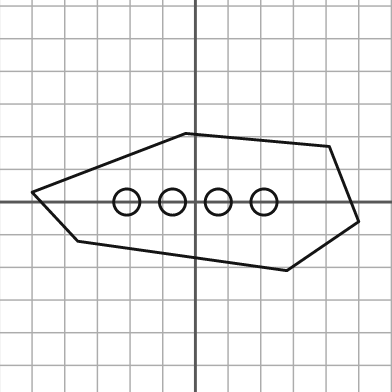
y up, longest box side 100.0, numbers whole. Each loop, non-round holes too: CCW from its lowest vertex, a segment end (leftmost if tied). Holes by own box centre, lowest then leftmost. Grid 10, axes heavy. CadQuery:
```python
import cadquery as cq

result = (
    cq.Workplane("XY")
    .moveTo(28.0, -21.0)
    .lineTo(50.0, -6.0)
    .lineTo(41.0, 17.0)
    .lineTo(-3.0, 21.0)
    .lineTo(-50.0, 3.0)
    .lineTo(-36.0, -12.0)
    .close()
    .moveTo(-21.0, 0.0)
    .circle(4.0)
    .moveTo(-7.0, 0.0)
    .circle(4.0)
    .moveTo(7.0, 0.0)
    .circle(4.0)
    .moveTo(21.0, 0.0)
    .circle(4.0)
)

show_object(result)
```